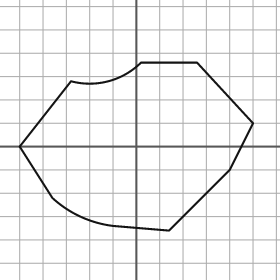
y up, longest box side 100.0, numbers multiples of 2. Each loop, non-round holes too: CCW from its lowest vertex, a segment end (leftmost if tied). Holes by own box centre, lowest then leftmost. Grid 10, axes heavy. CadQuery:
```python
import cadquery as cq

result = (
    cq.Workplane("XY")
    .moveTo(14.0, -36.0)
    .lineTo(40.0, -10.0)
    .lineTo(50.0, 10.0)
    .lineTo(26.0, 36.0)
    .lineTo(2.0, 36.0)
    .threePointArc((-12.0, 28.0), (-28.0, 28.0))
    .lineTo(-50.0, 0.0)
    .lineTo(-36.0, -22.0)
    .threePointArc((-24.0, -30.0), (-10.0, -34.0))
    .close()
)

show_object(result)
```